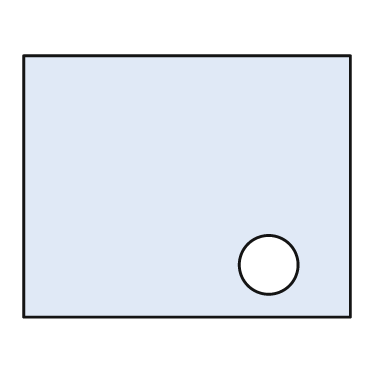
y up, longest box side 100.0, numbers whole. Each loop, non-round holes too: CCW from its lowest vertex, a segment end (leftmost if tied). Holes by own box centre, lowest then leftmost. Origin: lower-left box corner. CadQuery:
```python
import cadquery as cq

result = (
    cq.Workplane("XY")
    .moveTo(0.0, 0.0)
    .lineTo(100.0, 0.0)
    .lineTo(100.0, 80.0)
    .lineTo(0.0, 80.0)
    .close()
    .moveTo(75.0, 16.0)
    .circle(9.0)
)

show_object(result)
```